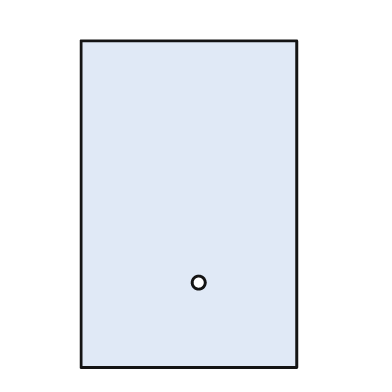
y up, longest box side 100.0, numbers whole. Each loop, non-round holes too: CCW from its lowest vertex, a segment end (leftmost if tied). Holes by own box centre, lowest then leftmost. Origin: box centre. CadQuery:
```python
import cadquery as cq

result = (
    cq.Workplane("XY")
    .moveTo(-33.0, -50.0)
    .lineTo(33.0, -50.0)
    .lineTo(33.0, 50.0)
    .lineTo(-33.0, 50.0)
    .close()
    .moveTo(3.0, -24.0)
    .circle(2.0)
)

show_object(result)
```